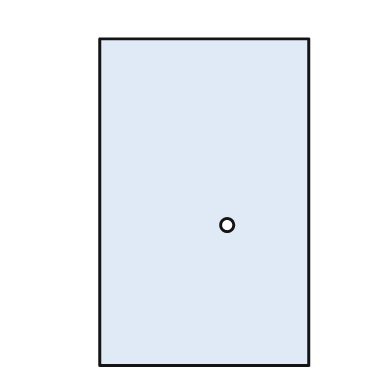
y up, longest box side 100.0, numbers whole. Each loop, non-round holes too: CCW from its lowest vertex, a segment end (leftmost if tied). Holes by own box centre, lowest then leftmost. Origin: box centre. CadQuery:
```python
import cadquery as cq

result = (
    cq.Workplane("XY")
    .moveTo(-32.0, -50.0)
    .lineTo(32.0, -50.0)
    .lineTo(32.0, 50.0)
    .lineTo(-32.0, 50.0)
    .close()
    .moveTo(7.0, -7.0)
    .circle(2.0)
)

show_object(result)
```